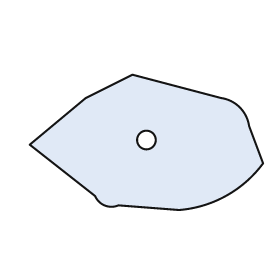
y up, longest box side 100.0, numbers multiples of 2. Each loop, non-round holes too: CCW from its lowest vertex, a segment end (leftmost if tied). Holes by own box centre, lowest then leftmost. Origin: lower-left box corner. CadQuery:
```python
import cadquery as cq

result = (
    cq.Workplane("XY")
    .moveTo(64.0, 0.0)
    .threePointArc((84.0, 6.0), (100.0, 20.0))
    .lineTo(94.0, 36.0)
    .threePointArc((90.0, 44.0), (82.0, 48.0))
    .lineTo(44.0, 58.0)
    .lineTo(24.0, 48.0)
    .lineTo(0.0, 28.0)
    .lineTo(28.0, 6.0)
    .threePointArc((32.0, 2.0), (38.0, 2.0))
    .close()
    .moveTo(50.0, 30.0)
    .circle(4.0)
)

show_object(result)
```